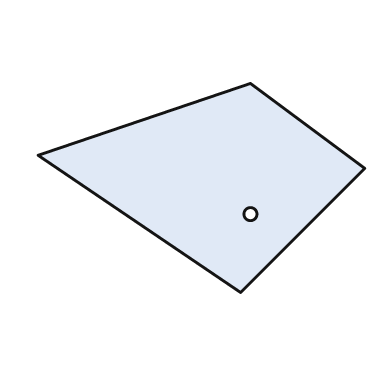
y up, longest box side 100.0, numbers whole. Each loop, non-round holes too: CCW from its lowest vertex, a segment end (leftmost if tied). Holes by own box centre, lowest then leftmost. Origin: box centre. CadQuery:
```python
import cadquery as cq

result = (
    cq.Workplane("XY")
    .moveTo(12.0, -32.0)
    .lineTo(50.0, 6.0)
    .lineTo(15.0, 32.0)
    .lineTo(-50.0, 10.0)
    .close()
    .moveTo(15.0, -8.0)
    .circle(2.0)
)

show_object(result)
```